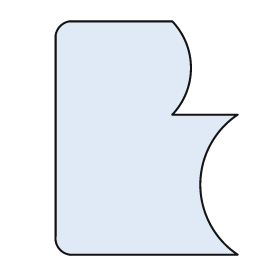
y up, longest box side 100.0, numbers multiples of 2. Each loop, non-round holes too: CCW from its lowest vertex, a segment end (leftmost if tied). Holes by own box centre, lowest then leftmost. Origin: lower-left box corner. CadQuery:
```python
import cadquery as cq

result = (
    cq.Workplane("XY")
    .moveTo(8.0, 0.0)
    .lineTo(78.0, 0.0)
    .threePointArc((62.0, 30.0), (78.0, 60.0))
    .lineTo(50.0, 60.0)
    .threePointArc((58.0, 80.0), (50.0, 100.0))
    .lineTo(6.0, 100.0)
    .threePointArc((2.0, 98.0), (0.0, 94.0))
    .lineTo(0.0, 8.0)
    .threePointArc((2.0, 2.0), (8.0, 0.0))
    .close()
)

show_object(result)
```